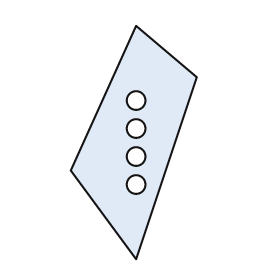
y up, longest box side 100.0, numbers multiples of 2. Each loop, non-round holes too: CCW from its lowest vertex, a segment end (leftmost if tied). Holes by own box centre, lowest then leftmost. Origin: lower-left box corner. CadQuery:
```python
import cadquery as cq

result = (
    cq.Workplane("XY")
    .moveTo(28.0, 0.0)
    .lineTo(54.0, 78.0)
    .lineTo(28.0, 100.0)
    .lineTo(0.0, 38.0)
    .close()
    .moveTo(28.0, 32.0)
    .circle(4.0)
    .moveTo(28.0, 44.0)
    .circle(4.0)
    .moveTo(28.0, 56.0)
    .circle(4.0)
    .moveTo(28.0, 68.0)
    .circle(4.0)
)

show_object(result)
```